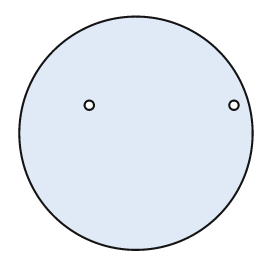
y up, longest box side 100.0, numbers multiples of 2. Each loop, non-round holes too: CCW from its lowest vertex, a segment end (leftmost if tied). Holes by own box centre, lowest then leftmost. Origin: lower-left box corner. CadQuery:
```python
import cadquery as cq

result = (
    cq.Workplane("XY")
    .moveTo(50.0, 50.0)
    .circle(50.0)
    .moveTo(30.0, 62.0)
    .circle(2.0)
    .moveTo(92.0, 62.0)
    .circle(2.0)
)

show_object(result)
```